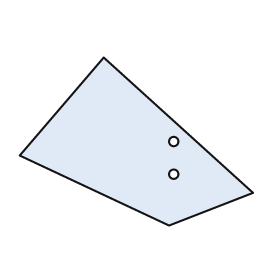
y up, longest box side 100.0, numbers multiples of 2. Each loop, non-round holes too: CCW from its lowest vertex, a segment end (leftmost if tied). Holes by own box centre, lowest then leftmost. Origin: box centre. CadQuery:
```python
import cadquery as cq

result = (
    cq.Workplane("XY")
    .moveTo(14.0, -36.0)
    .lineTo(50.0, -22.0)
    .lineTo(-14.0, 36.0)
    .lineTo(-50.0, -6.0)
    .close()
    .moveTo(16.0, -14.0)
    .circle(2.0)
    .moveTo(16.0, 0.0)
    .circle(2.0)
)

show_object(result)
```